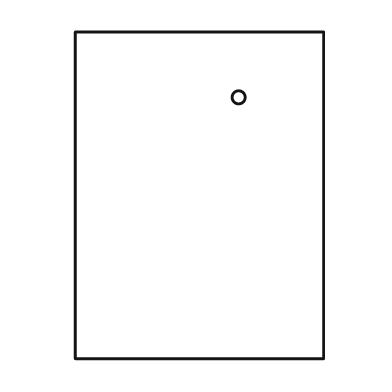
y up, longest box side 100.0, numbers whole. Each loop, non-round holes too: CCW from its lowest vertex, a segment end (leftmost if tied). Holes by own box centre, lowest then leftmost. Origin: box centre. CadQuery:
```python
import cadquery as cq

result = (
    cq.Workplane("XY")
    .moveTo(-38.0, -50.0)
    .lineTo(38.0, -50.0)
    .lineTo(38.0, 50.0)
    .lineTo(-38.0, 50.0)
    .close()
    .moveTo(12.0, 30.0)
    .circle(2.0)
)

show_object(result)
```